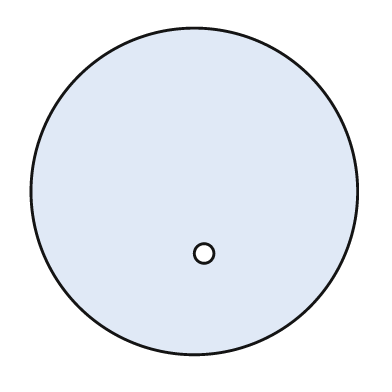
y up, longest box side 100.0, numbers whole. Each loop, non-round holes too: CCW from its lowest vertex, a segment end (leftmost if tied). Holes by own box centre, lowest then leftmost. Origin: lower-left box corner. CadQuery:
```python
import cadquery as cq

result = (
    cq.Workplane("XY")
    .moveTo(50.0, 50.0)
    .circle(50.0)
    .moveTo(53.0, 31.0)
    .circle(3.0)
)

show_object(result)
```